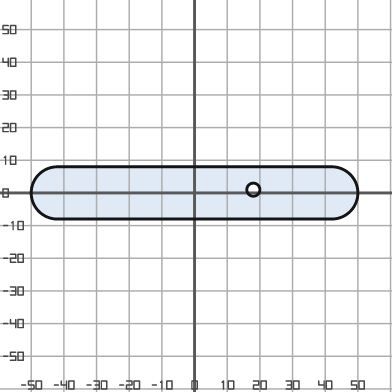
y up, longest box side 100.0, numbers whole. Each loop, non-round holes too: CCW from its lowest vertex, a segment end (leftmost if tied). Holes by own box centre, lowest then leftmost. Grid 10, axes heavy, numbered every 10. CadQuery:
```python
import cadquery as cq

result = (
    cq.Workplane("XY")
    .moveTo(-42.0, -8.0)
    .lineTo(42.0, -8.0)
    .threePointArc((50.0, 0.0), (42.0, 8.0))
    .lineTo(-42.0, 8.0)
    .threePointArc((-50.0, 0.0), (-42.0, -8.0))
    .close()
    .moveTo(18.0, 1.0)
    .circle(2.0)
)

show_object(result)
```